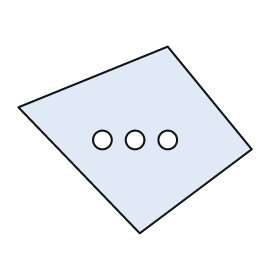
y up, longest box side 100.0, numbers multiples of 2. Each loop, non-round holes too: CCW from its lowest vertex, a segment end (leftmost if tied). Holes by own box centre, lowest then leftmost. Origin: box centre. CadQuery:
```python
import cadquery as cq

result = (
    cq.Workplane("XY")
    .moveTo(2.0, -40.0)
    .lineTo(50.0, -4.0)
    .lineTo(14.0, 40.0)
    .lineTo(-50.0, 14.0)
    .close()
    .moveTo(-14.0, 0.0)
    .circle(4.0)
    .moveTo(0.0, 0.0)
    .circle(4.0)
    .moveTo(14.0, 0.0)
    .circle(4.0)
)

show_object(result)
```